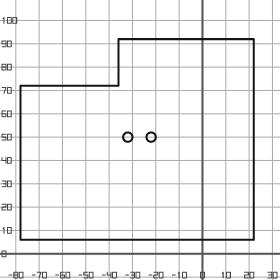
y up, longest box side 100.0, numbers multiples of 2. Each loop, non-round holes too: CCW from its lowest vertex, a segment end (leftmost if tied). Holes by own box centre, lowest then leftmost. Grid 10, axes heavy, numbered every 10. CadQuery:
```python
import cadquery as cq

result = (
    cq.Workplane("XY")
    .moveTo(-78.0, 6.0)
    .lineTo(22.0, 6.0)
    .lineTo(22.0, 92.0)
    .lineTo(-36.0, 92.0)
    .lineTo(-36.0, 72.0)
    .lineTo(-78.0, 72.0)
    .close()
    .moveTo(-32.0, 50.0)
    .circle(2.0)
    .moveTo(-22.0, 50.0)
    .circle(2.0)
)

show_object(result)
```